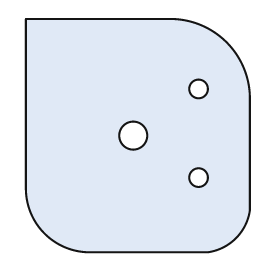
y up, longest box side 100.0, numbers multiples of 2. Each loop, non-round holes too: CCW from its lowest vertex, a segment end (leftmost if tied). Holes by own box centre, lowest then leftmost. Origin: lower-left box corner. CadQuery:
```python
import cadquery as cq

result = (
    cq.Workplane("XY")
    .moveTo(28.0, 0.0)
    .lineTo(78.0, 0.0)
    .threePointArc((90.0, 6.0), (96.0, 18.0))
    .lineTo(96.0, 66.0)
    .threePointArc((86.0, 90.0), (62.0, 100.0))
    .lineTo(0.0, 100.0)
    .lineTo(0.0, 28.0)
    .threePointArc((8.0, 8.0), (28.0, 0.0))
    .close()
    .moveTo(74.0, 32.0)
    .circle(4.0)
    .moveTo(46.0, 50.0)
    .circle(6.0)
    .moveTo(74.0, 70.0)
    .circle(4.0)
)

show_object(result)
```